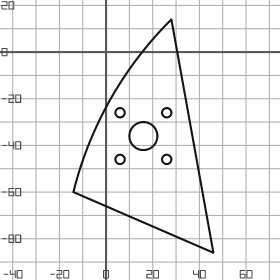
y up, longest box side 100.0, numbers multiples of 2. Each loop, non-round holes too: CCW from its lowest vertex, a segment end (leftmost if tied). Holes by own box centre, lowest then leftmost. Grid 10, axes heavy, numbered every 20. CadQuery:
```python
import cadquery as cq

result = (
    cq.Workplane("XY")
    .moveTo(46.0, -86.0)
    .lineTo(28.0, 14.0)
    .threePointArc((2.0, -20.0), (-14.0, -60.0))
    .close()
    .moveTo(6.0, -46.0)
    .circle(2.0)
    .moveTo(26.0, -46.0)
    .circle(2.0)
    .moveTo(16.0, -36.0)
    .circle(6.0)
    .moveTo(6.0, -26.0)
    .circle(2.0)
    .moveTo(26.0, -26.0)
    .circle(2.0)
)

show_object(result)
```